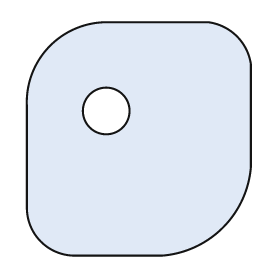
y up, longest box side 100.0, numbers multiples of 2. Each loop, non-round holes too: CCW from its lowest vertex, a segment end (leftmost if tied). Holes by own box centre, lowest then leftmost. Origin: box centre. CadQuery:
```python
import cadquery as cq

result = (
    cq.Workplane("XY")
    .moveTo(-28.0, -50.0)
    .lineTo(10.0, -50.0)
    .threePointArc((36.0, -38.0), (48.0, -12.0))
    .lineTo(48.0, 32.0)
    .threePointArc((42.0, 44.0), (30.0, 50.0))
    .lineTo(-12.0, 50.0)
    .threePointArc((-38.0, 40.0), (-48.0, 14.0))
    .lineTo(-48.0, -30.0)
    .threePointArc((-42.0, -44.0), (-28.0, -50.0))
    .close()
    .moveTo(-14.0, 12.0)
    .circle(10.0)
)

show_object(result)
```